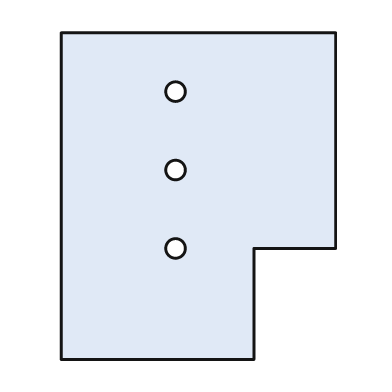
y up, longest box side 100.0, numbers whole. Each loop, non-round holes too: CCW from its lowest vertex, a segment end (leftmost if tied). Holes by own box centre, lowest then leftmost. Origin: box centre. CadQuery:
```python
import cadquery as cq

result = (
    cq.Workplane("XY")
    .moveTo(-42.0, -50.0)
    .lineTo(17.0, -50.0)
    .lineTo(17.0, -16.0)
    .lineTo(42.0, -16.0)
    .lineTo(42.0, 50.0)
    .lineTo(-42.0, 50.0)
    .close()
    .moveTo(-7.0, -16.0)
    .circle(3.0)
    .moveTo(-7.0, 8.0)
    .circle(3.0)
    .moveTo(-7.0, 32.0)
    .circle(3.0)
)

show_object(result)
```